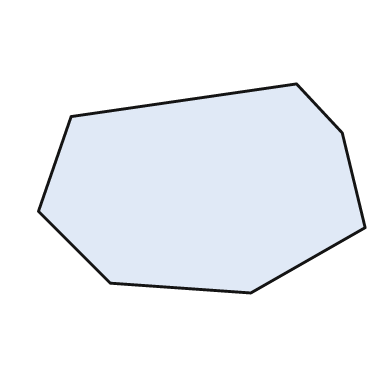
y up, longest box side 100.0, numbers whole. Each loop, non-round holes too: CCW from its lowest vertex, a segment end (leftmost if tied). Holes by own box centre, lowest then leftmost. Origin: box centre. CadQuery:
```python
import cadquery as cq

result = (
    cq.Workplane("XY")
    .moveTo(15.0, -32.0)
    .lineTo(50.0, -12.0)
    .lineTo(43.0, 17.0)
    .lineTo(29.0, 32.0)
    .lineTo(-40.0, 22.0)
    .lineTo(-50.0, -7.0)
    .lineTo(-28.0, -29.0)
    .close()
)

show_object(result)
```